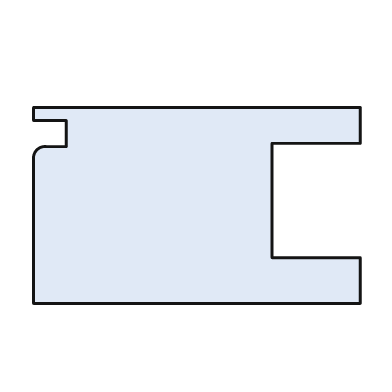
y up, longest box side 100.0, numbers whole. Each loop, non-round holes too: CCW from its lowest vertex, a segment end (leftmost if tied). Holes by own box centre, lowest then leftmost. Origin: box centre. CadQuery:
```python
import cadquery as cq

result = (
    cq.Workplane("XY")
    .moveTo(-50.0, -30.0)
    .lineTo(50.0, -30.0)
    .lineTo(50.0, -16.0)
    .lineTo(23.0, -16.0)
    .lineTo(23.0, 19.0)
    .lineTo(50.0, 19.0)
    .lineTo(50.0, 30.0)
    .lineTo(-50.0, 30.0)
    .lineTo(-50.0, 26.0)
    .lineTo(-40.0, 26.0)
    .lineTo(-40.0, 18.0)
    .lineTo(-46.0, 18.0)
    .threePointArc((-49.0, 17.0), (-50.0, 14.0))
    .close()
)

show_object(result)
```